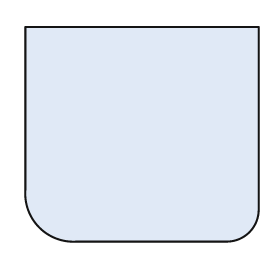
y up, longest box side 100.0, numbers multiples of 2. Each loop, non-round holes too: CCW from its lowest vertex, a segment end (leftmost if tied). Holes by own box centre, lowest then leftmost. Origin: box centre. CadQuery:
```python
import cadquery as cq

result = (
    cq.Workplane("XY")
    .moveTo(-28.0, -46.0)
    .lineTo(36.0, -46.0)
    .threePointArc((46.0, -42.0), (50.0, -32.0))
    .lineTo(50.0, 46.0)
    .lineTo(-50.0, 46.0)
    .lineTo(-50.0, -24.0)
    .threePointArc((-44.0, -40.0), (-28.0, -46.0))
    .close()
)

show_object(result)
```